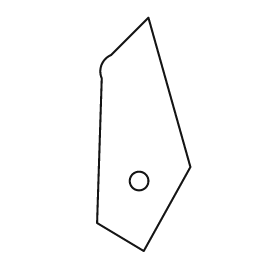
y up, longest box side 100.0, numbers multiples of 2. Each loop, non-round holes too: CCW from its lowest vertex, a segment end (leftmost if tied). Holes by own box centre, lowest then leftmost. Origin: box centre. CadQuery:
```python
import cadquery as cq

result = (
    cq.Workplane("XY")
    .moveTo(0.0, -50.0)
    .lineTo(20.0, -14.0)
    .lineTo(2.0, 50.0)
    .lineTo(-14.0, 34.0)
    .threePointArc((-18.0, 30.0), (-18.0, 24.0))
    .lineTo(-20.0, -38.0)
    .close()
    .moveTo(-2.0, -20.0)
    .circle(4.0)
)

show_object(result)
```